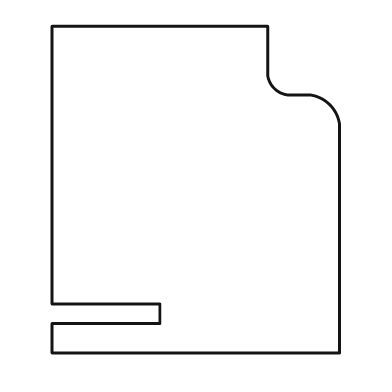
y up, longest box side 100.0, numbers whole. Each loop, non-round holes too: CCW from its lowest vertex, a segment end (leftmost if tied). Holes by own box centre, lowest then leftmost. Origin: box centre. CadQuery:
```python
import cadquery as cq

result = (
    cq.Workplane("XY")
    .moveTo(-44.0, -50.0)
    .lineTo(44.0, -50.0)
    .lineTo(44.0, 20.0)
    .threePointArc((41.0, 26.0), (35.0, 29.0))
    .lineTo(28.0, 29.0)
    .threePointArc((24.0, 31.0), (22.0, 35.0))
    .lineTo(22.0, 50.0)
    .lineTo(-44.0, 50.0)
    .lineTo(-44.0, -35.0)
    .lineTo(-11.0, -35.0)
    .lineTo(-11.0, -41.0)
    .lineTo(-44.0, -41.0)
    .close()
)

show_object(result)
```